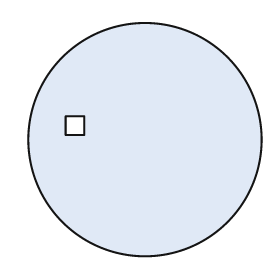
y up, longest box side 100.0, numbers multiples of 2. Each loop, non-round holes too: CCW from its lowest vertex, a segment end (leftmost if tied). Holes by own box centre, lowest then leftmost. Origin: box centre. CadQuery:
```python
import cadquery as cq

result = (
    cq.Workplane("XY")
    .moveTo(0.0, 0.0)
    .circle(50.0)
    .moveTo(-34.0, 2.0)
    .lineTo(-26.0, 2.0)
    .lineTo(-26.0, 10.0)
    .lineTo(-34.0, 10.0)
    .close()
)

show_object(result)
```